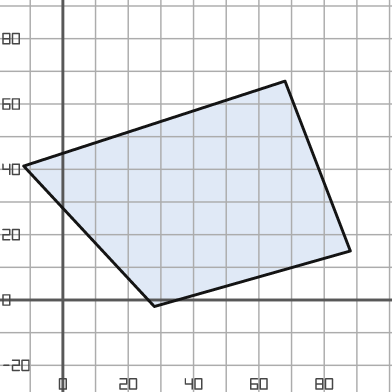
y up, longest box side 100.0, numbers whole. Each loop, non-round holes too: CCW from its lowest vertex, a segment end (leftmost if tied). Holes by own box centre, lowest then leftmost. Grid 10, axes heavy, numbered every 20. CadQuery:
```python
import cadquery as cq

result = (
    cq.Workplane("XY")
    .moveTo(28.0, -2.0)
    .lineTo(88.0, 15.0)
    .lineTo(68.0, 67.0)
    .lineTo(-12.0, 41.0)
    .close()
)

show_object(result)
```